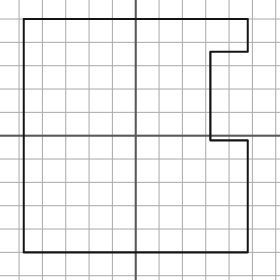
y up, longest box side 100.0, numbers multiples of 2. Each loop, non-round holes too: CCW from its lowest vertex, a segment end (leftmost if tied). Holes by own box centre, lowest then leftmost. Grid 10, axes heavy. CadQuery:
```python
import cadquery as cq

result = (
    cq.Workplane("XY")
    .moveTo(-48.0, -50.0)
    .lineTo(48.0, -50.0)
    .lineTo(48.0, -2.0)
    .lineTo(32.0, -2.0)
    .lineTo(32.0, 36.0)
    .lineTo(48.0, 36.0)
    .lineTo(48.0, 50.0)
    .lineTo(-48.0, 50.0)
    .close()
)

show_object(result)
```